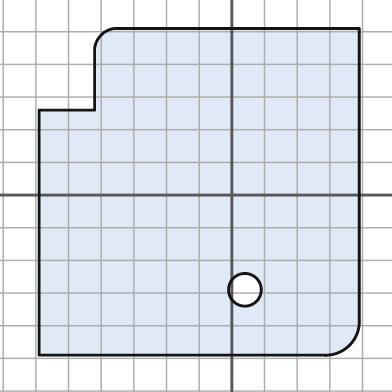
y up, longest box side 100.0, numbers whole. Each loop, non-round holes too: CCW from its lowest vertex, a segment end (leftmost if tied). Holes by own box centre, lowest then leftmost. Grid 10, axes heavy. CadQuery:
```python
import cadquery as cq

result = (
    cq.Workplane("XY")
    .moveTo(-59.0, -49.0)
    .lineTo(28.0, -49.0)
    .threePointArc((36.0, -46.0), (39.0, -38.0))
    .lineTo(39.0, 51.0)
    .lineTo(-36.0, 51.0)
    .threePointArc((-40.0, 49.0), (-42.0, 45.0))
    .lineTo(-42.0, 26.0)
    .lineTo(-59.0, 26.0)
    .close()
    .moveTo(4.0, -29.0)
    .circle(5.0)
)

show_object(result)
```